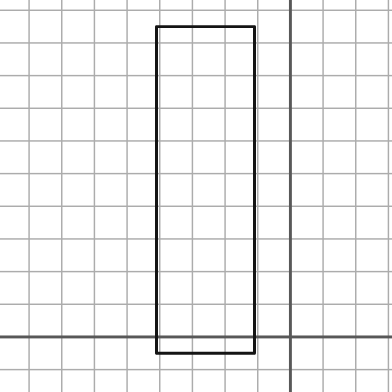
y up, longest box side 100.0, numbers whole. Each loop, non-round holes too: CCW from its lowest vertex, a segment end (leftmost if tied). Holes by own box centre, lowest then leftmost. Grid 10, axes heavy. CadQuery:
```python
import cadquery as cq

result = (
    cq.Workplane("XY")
    .moveTo(-41.0, -5.0)
    .lineTo(-11.0, -5.0)
    .lineTo(-11.0, 95.0)
    .lineTo(-41.0, 95.0)
    .close()
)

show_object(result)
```